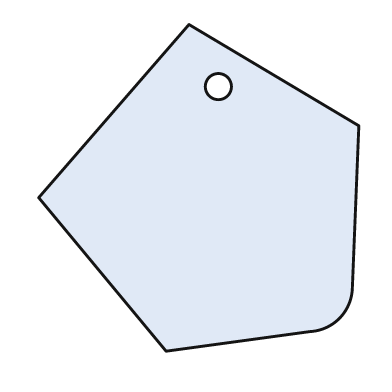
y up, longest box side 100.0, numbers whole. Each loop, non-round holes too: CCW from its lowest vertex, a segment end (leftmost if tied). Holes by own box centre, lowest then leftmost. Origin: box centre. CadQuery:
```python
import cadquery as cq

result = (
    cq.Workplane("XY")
    .moveTo(-10.0, -50.0)
    .lineTo(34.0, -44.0)
    .threePointArc((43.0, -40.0), (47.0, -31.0))
    .lineTo(49.0, 19.0)
    .lineTo(-3.0, 50.0)
    .lineTo(-49.0, -3.0)
    .close()
    .moveTo(6.0, 31.0)
    .circle(4.0)
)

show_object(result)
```